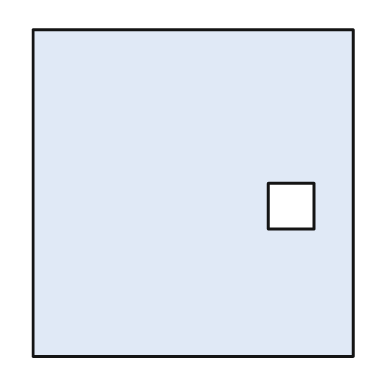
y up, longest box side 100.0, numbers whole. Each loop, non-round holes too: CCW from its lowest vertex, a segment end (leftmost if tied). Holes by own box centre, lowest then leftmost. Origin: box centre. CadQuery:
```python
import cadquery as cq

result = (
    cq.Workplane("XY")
    .moveTo(-49.0, -50.0)
    .lineTo(49.0, -50.0)
    .lineTo(49.0, 50.0)
    .lineTo(-49.0, 50.0)
    .close()
    .moveTo(23.0, -11.0)
    .lineTo(37.0, -11.0)
    .lineTo(37.0, 3.0)
    .lineTo(23.0, 3.0)
    .close()
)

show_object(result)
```